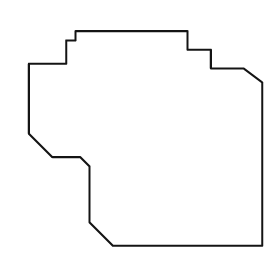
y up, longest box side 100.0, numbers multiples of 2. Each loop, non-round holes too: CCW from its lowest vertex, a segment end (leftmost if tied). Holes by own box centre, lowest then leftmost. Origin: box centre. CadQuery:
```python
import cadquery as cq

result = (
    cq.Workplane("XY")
    .moveTo(-14.0, -46.0)
    .lineTo(50.0, -46.0)
    .lineTo(50.0, 24.0)
    .lineTo(42.0, 30.0)
    .lineTo(28.0, 30.0)
    .lineTo(28.0, 38.0)
    .lineTo(18.0, 38.0)
    .lineTo(18.0, 46.0)
    .lineTo(-30.0, 46.0)
    .lineTo(-30.0, 42.0)
    .lineTo(-34.0, 42.0)
    .lineTo(-34.0, 32.0)
    .lineTo(-50.0, 32.0)
    .lineTo(-50.0, 2.0)
    .lineTo(-40.0, -8.0)
    .lineTo(-28.0, -8.0)
    .lineTo(-24.0, -12.0)
    .lineTo(-24.0, -36.0)
    .close()
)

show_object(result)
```